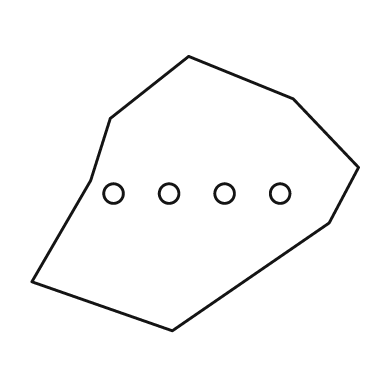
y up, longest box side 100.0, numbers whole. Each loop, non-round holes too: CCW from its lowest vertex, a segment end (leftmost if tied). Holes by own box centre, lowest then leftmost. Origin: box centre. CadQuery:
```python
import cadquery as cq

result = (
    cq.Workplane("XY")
    .moveTo(-7.0, -42.0)
    .lineTo(41.0, -9.0)
    .lineTo(50.0, 8.0)
    .lineTo(30.0, 29.0)
    .lineTo(-2.0, 42.0)
    .lineTo(-26.0, 23.0)
    .lineTo(-32.0, 4.0)
    .lineTo(-50.0, -27.0)
    .close()
    .moveTo(-25.0, 0.0)
    .circle(3.0)
    .moveTo(-8.0, 0.0)
    .circle(3.0)
    .moveTo(9.0, 0.0)
    .circle(3.0)
    .moveTo(26.0, 0.0)
    .circle(3.0)
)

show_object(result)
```